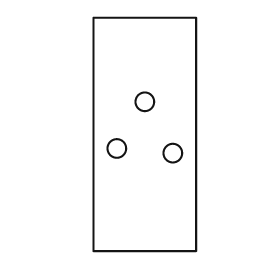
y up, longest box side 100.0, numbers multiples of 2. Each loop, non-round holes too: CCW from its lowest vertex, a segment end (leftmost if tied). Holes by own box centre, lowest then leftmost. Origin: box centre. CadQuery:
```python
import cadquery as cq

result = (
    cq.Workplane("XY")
    .moveTo(-22.0, -50.0)
    .lineTo(22.0, -50.0)
    .lineTo(22.0, 50.0)
    .lineTo(-22.0, 50.0)
    .close()
    .moveTo(12.0, -8.0)
    .circle(4.0)
    .moveTo(-12.0, -6.0)
    .circle(4.0)
    .moveTo(0.0, 14.0)
    .circle(4.0)
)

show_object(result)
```